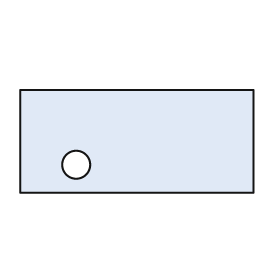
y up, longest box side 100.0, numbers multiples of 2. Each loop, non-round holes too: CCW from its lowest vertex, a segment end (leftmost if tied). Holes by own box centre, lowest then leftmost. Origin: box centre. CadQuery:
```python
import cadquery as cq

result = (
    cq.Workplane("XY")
    .moveTo(-50.0, -22.0)
    .lineTo(50.0, -22.0)
    .lineTo(50.0, 22.0)
    .lineTo(-50.0, 22.0)
    .close()
    .moveTo(-26.0, -10.0)
    .circle(6.0)
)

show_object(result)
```